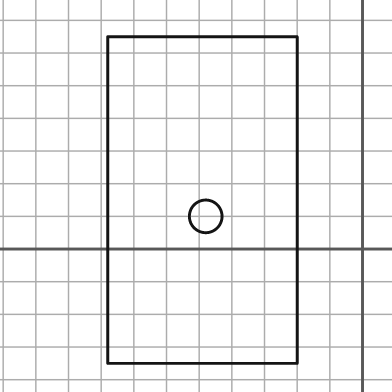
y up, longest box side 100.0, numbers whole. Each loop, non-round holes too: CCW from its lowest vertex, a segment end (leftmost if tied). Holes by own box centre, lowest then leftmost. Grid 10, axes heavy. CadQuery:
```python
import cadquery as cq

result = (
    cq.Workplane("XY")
    .moveTo(-78.0, -35.0)
    .lineTo(-20.0, -35.0)
    .lineTo(-20.0, 65.0)
    .lineTo(-78.0, 65.0)
    .close()
    .moveTo(-48.0, 10.0)
    .circle(5.0)
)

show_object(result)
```